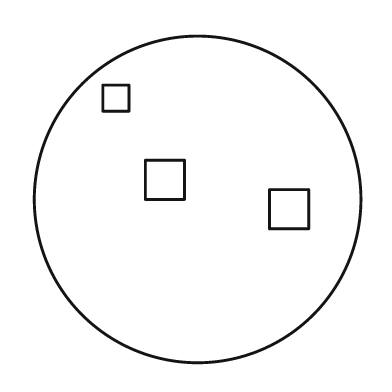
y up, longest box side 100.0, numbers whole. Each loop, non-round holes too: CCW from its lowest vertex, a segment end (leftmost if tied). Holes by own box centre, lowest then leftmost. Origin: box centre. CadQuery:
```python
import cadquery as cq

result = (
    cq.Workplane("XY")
    .moveTo(0.0, 0.0)
    .circle(50.0)
    .moveTo(22.0, -9.0)
    .lineTo(34.0, -9.0)
    .lineTo(34.0, 3.0)
    .lineTo(22.0, 3.0)
    .close()
    .moveTo(-16.0, 0.0)
    .lineTo(-4.0, 0.0)
    .lineTo(-4.0, 12.0)
    .lineTo(-16.0, 12.0)
    .close()
    .moveTo(-29.0, 27.0)
    .lineTo(-21.0, 27.0)
    .lineTo(-21.0, 35.0)
    .lineTo(-29.0, 35.0)
    .close()
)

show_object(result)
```